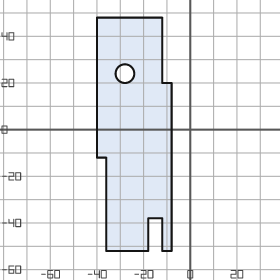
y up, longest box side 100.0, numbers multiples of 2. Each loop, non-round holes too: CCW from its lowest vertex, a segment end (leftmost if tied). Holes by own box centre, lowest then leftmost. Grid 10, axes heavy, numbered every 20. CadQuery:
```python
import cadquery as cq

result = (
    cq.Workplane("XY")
    .moveTo(-36.0, -52.0)
    .lineTo(-18.0, -52.0)
    .lineTo(-18.0, -38.0)
    .lineTo(-12.0, -38.0)
    .lineTo(-12.0, -52.0)
    .lineTo(-8.0, -52.0)
    .lineTo(-8.0, 20.0)
    .lineTo(-12.0, 20.0)
    .lineTo(-12.0, 48.0)
    .lineTo(-40.0, 48.0)
    .lineTo(-40.0, -12.0)
    .lineTo(-36.0, -12.0)
    .close()
    .moveTo(-28.0, 24.0)
    .circle(4.0)
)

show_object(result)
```